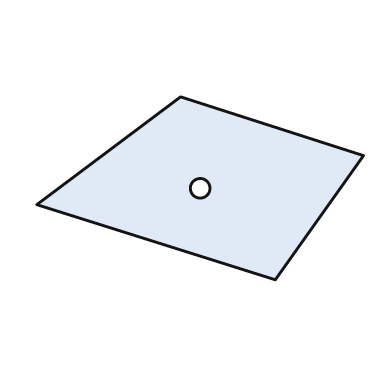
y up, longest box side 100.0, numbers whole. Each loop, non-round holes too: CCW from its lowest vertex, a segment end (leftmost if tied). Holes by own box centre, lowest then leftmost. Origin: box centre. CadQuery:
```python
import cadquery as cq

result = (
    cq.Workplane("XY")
    .moveTo(23.0, -28.0)
    .lineTo(50.0, 10.0)
    .lineTo(-6.0, 28.0)
    .lineTo(-50.0, -5.0)
    .close()
    .moveTo(0.0, 0.0)
    .circle(3.0)
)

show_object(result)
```